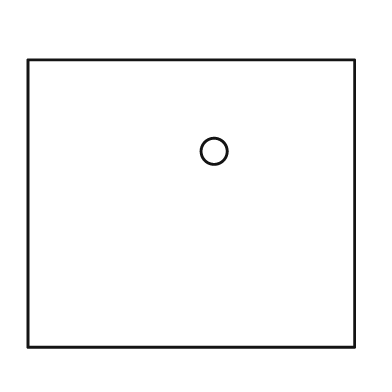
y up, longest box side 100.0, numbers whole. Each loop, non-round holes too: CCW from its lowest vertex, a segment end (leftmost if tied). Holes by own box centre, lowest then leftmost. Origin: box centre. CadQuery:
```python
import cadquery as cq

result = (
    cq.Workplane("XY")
    .moveTo(-50.0, -44.0)
    .lineTo(50.0, -44.0)
    .lineTo(50.0, 44.0)
    .lineTo(-50.0, 44.0)
    .close()
    .moveTo(7.0, 16.0)
    .circle(4.0)
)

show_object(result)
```